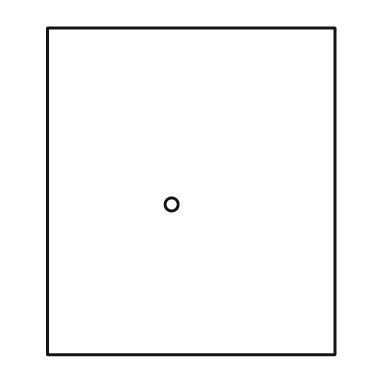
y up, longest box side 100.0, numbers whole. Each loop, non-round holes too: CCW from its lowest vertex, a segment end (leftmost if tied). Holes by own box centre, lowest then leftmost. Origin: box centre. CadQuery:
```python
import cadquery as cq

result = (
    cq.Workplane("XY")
    .moveTo(-44.0, -50.0)
    .lineTo(44.0, -50.0)
    .lineTo(44.0, 50.0)
    .lineTo(-44.0, 50.0)
    .close()
    .moveTo(-6.0, -4.0)
    .circle(2.0)
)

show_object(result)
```